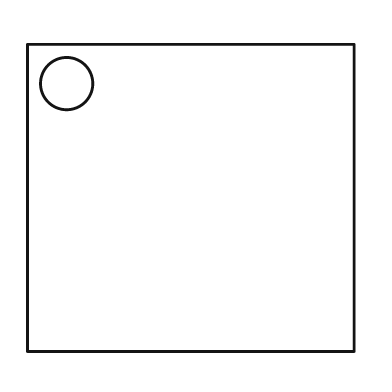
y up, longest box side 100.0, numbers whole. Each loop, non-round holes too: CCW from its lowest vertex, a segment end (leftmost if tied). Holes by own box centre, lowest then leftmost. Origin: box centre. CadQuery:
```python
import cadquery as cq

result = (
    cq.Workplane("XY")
    .moveTo(-50.0, -47.0)
    .lineTo(50.0, -47.0)
    .lineTo(50.0, 47.0)
    .lineTo(-50.0, 47.0)
    .close()
    .moveTo(-38.0, 35.0)
    .circle(8.0)
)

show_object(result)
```